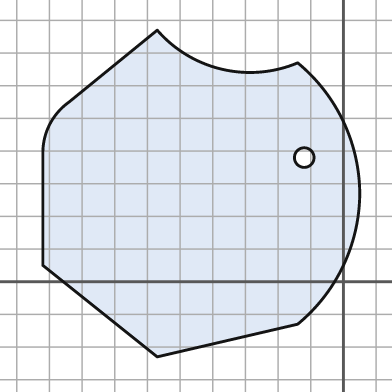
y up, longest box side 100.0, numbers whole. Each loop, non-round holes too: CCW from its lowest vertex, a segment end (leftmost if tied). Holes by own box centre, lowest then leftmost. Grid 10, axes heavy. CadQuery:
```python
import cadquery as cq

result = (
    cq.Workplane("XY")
    .moveTo(-57.0, -23.0)
    .lineTo(-14.0, -13.0)
    .threePointArc((0.0, 5.0), (5.0, 27.0))
    .threePointArc((0.0, 49.0), (-14.0, 67.0))
    .threePointArc((-37.0, 65.0), (-57.0, 77.0))
    .lineTo(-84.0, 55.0)
    .threePointArc((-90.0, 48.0), (-92.0, 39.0))
    .lineTo(-92.0, 5.0)
    .close()
    .moveTo(-12.0, 38.0)
    .circle(3.0)
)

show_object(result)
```